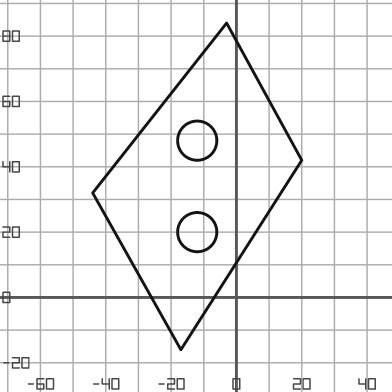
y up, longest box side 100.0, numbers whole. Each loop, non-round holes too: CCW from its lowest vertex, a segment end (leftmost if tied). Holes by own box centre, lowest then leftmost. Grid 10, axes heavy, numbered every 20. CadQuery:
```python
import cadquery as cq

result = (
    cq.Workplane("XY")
    .moveTo(-17.0, -16.0)
    .lineTo(20.0, 42.0)
    .lineTo(-3.0, 84.0)
    .lineTo(-44.0, 32.0)
    .close()
    .moveTo(-12.0, 20.0)
    .circle(6.0)
    .moveTo(-12.0, 48.0)
    .circle(6.0)
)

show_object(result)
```